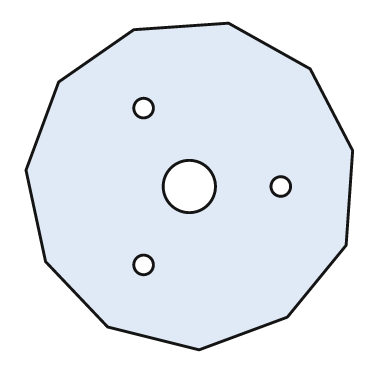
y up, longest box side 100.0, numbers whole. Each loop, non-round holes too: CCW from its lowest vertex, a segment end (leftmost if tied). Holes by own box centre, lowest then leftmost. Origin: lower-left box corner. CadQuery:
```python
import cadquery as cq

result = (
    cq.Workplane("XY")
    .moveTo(53.0, 0.0)
    .lineTo(80.0, 10.0)
    .lineTo(98.0, 32.0)
    .lineTo(100.0, 61.0)
    .lineTo(87.0, 86.0)
    .lineTo(62.0, 100.0)
    .lineTo(33.0, 98.0)
    .lineTo(10.0, 82.0)
    .lineTo(0.0, 55.0)
    .lineTo(6.0, 27.0)
    .lineTo(25.0, 7.0)
    .close()
    .moveTo(36.0, 26.0)
    .circle(3.0)
    .moveTo(50.0, 50.0)
    .circle(8.0)
    .moveTo(78.0, 50.0)
    .circle(3.0)
    .moveTo(36.0, 74.0)
    .circle(3.0)
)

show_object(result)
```